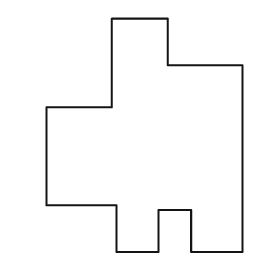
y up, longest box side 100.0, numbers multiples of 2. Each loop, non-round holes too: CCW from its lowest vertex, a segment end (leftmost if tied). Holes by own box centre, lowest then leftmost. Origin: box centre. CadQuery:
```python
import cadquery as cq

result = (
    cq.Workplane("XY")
    .moveTo(-12.0, -50.0)
    .lineTo(6.0, -50.0)
    .lineTo(6.0, -32.0)
    .lineTo(20.0, -32.0)
    .lineTo(20.0, -50.0)
    .lineTo(42.0, -50.0)
    .lineTo(42.0, 30.0)
    .lineTo(10.0, 30.0)
    .lineTo(10.0, 50.0)
    .lineTo(-14.0, 50.0)
    .lineTo(-14.0, 12.0)
    .lineTo(-42.0, 12.0)
    .lineTo(-42.0, -30.0)
    .lineTo(-12.0, -30.0)
    .close()
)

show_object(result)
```